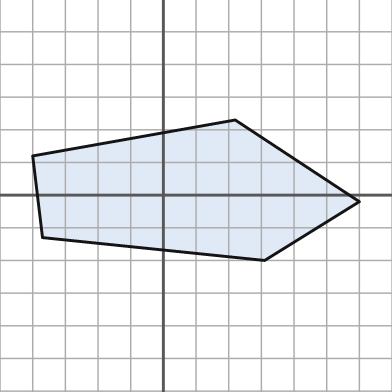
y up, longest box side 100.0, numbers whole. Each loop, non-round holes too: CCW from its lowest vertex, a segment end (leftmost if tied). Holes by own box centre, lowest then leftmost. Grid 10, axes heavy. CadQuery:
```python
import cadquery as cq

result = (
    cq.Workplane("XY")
    .moveTo(31.0, -20.0)
    .lineTo(60.0, -2.0)
    .lineTo(22.0, 23.0)
    .lineTo(-40.0, 12.0)
    .lineTo(-37.0, -13.0)
    .close()
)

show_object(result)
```